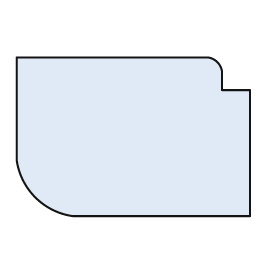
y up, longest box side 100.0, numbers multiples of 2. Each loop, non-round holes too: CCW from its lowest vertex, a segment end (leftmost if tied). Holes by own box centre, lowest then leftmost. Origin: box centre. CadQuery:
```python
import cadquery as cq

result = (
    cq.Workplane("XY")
    .moveTo(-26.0, -34.0)
    .lineTo(50.0, -34.0)
    .lineTo(50.0, 20.0)
    .lineTo(38.0, 20.0)
    .lineTo(38.0, 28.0)
    .threePointArc((36.0, 32.0), (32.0, 34.0))
    .lineTo(-50.0, 34.0)
    .lineTo(-50.0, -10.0)
    .threePointArc((-42.0, -26.0), (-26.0, -34.0))
    .close()
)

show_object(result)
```